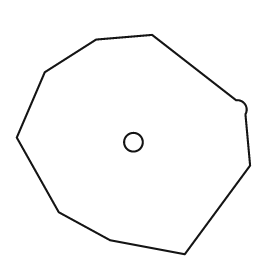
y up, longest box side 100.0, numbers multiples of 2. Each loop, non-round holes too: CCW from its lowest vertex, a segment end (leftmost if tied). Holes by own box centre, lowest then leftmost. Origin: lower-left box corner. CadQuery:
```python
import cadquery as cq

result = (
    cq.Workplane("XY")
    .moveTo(72.0, 0.0)
    .lineTo(100.0, 38.0)
    .lineTo(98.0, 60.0)
    .threePointArc((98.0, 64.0), (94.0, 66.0))
    .lineTo(58.0, 94.0)
    .lineTo(34.0, 92.0)
    .lineTo(12.0, 78.0)
    .lineTo(0.0, 50.0)
    .lineTo(18.0, 18.0)
    .lineTo(40.0, 6.0)
    .close()
    .moveTo(50.0, 48.0)
    .circle(4.0)
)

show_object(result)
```